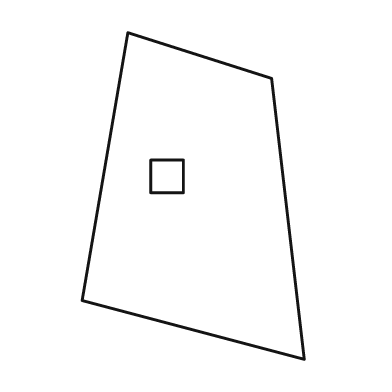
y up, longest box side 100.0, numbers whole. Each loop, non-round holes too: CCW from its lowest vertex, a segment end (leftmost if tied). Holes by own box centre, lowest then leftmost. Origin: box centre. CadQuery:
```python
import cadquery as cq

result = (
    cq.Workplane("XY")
    .moveTo(34.0, -50.0)
    .lineTo(24.0, 36.0)
    .lineTo(-20.0, 50.0)
    .lineTo(-34.0, -32.0)
    .close()
    .moveTo(-13.0, 1.0)
    .lineTo(-3.0, 1.0)
    .lineTo(-3.0, 11.0)
    .lineTo(-13.0, 11.0)
    .close()
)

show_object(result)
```